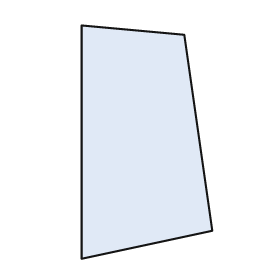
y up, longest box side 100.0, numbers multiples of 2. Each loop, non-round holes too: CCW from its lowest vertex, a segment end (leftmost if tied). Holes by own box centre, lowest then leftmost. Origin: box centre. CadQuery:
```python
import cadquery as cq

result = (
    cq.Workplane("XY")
    .moveTo(-28.0, -50.0)
    .lineTo(28.0, -38.0)
    .lineTo(16.0, 46.0)
    .lineTo(-28.0, 50.0)
    .close()
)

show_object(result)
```